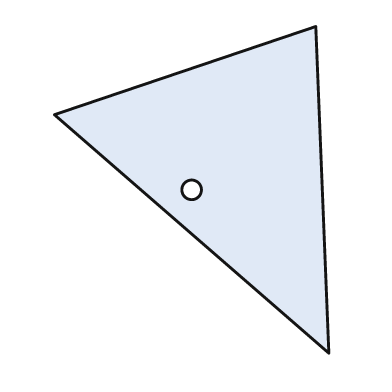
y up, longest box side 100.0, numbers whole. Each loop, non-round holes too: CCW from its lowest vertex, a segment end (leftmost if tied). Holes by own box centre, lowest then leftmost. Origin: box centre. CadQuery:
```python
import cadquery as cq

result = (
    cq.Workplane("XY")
    .moveTo(42.0, -50.0)
    .lineTo(38.0, 50.0)
    .lineTo(-42.0, 23.0)
    .close()
    .moveTo(0.0, 0.0)
    .circle(3.0)
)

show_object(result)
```